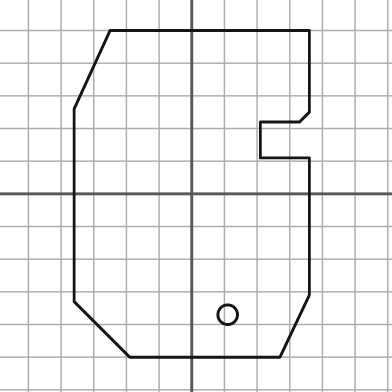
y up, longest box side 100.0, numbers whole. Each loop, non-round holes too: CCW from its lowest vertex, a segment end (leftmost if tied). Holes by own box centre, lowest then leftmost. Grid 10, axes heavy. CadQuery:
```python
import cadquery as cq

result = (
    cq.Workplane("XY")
    .moveTo(-19.0, -50.0)
    .lineTo(27.0, -50.0)
    .lineTo(36.0, -31.0)
    .lineTo(36.0, 11.0)
    .lineTo(21.0, 11.0)
    .lineTo(21.0, 22.0)
    .lineTo(33.0, 22.0)
    .lineTo(36.0, 25.0)
    .lineTo(36.0, 50.0)
    .lineTo(-25.0, 50.0)
    .lineTo(-36.0, 26.0)
    .lineTo(-36.0, -33.0)
    .close()
    .moveTo(11.0, -37.0)
    .circle(3.0)
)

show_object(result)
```